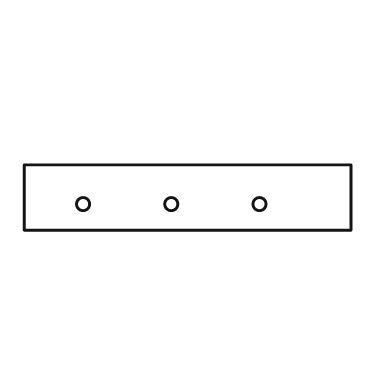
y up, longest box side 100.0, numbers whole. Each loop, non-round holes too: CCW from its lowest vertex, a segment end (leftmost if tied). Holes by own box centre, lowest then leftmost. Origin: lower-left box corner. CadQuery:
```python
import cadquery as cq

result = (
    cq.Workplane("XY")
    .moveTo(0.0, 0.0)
    .lineTo(100.0, 0.0)
    .lineTo(100.0, 20.0)
    .lineTo(0.0, 20.0)
    .close()
    .moveTo(18.0, 8.0)
    .circle(2.0)
    .moveTo(45.0, 8.0)
    .circle(2.0)
    .moveTo(72.0, 8.0)
    .circle(2.0)
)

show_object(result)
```